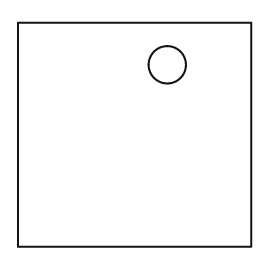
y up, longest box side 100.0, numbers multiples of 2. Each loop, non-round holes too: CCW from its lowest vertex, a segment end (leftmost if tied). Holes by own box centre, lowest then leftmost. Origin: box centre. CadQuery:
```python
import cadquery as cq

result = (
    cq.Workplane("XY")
    .moveTo(-50.0, -48.0)
    .lineTo(50.0, -48.0)
    .lineTo(50.0, 48.0)
    .lineTo(-50.0, 48.0)
    .close()
    .moveTo(14.0, 30.0)
    .circle(8.0)
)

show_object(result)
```